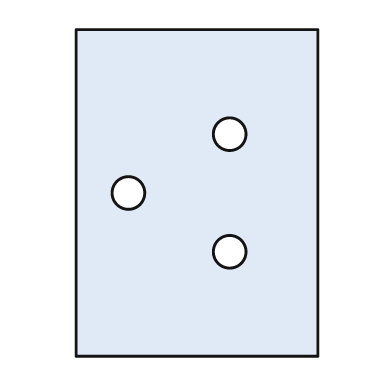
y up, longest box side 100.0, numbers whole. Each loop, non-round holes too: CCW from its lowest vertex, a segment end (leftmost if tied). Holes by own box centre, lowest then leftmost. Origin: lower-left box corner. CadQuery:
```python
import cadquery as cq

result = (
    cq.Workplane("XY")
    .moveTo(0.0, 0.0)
    .lineTo(74.0, 0.0)
    .lineTo(74.0, 100.0)
    .lineTo(0.0, 100.0)
    .close()
    .moveTo(47.0, 32.0)
    .circle(5.0)
    .moveTo(16.0, 50.0)
    .circle(5.0)
    .moveTo(47.0, 68.0)
    .circle(5.0)
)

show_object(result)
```